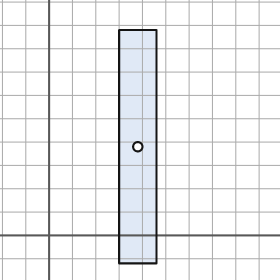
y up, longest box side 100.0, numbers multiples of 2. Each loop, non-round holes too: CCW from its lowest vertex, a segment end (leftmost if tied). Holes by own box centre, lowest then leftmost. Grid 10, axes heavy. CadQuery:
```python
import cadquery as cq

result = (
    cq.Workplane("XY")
    .moveTo(30.0, -12.0)
    .lineTo(46.0, -12.0)
    .lineTo(46.0, 88.0)
    .lineTo(30.0, 88.0)
    .close()
    .moveTo(38.0, 38.0)
    .circle(2.0)
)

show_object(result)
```